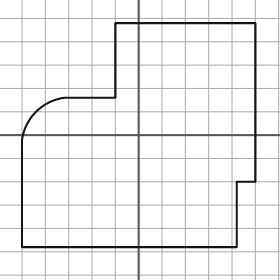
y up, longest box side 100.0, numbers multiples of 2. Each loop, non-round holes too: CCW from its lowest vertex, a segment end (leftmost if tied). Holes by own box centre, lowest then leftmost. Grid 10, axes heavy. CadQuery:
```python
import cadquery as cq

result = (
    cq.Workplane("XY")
    .moveTo(-50.0, -48.0)
    .lineTo(42.0, -48.0)
    .lineTo(42.0, -20.0)
    .lineTo(50.0, -20.0)
    .lineTo(50.0, 48.0)
    .lineTo(-10.0, 48.0)
    .lineTo(-10.0, 16.0)
    .lineTo(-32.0, 16.0)
    .threePointArc((-44.0, 10.0), (-50.0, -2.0))
    .close()
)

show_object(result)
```